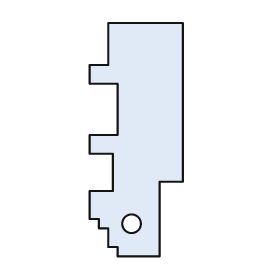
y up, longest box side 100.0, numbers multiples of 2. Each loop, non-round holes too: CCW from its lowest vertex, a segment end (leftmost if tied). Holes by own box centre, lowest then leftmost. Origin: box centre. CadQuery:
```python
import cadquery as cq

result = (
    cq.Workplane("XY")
    .moveTo(-8.0, -50.0)
    .lineTo(10.0, -50.0)
    .lineTo(10.0, -18.0)
    .lineTo(20.0, -18.0)
    .lineTo(20.0, 50.0)
    .lineTo(-12.0, 50.0)
    .lineTo(-12.0, 32.0)
    .lineTo(-20.0, 32.0)
    .lineTo(-20.0, 24.0)
    .lineTo(-8.0, 24.0)
    .lineTo(-8.0, 2.0)
    .lineTo(-20.0, 2.0)
    .lineTo(-20.0, -6.0)
    .lineTo(-10.0, -6.0)
    .lineTo(-10.0, -22.0)
    .lineTo(-20.0, -22.0)
    .lineTo(-20.0, -34.0)
    .lineTo(-16.0, -34.0)
    .lineTo(-16.0, -38.0)
    .lineTo(-12.0, -38.0)
    .lineTo(-12.0, -46.0)
    .lineTo(-8.0, -46.0)
    .close()
    .moveTo(-2.0, -36.0)
    .circle(4.0)
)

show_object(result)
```